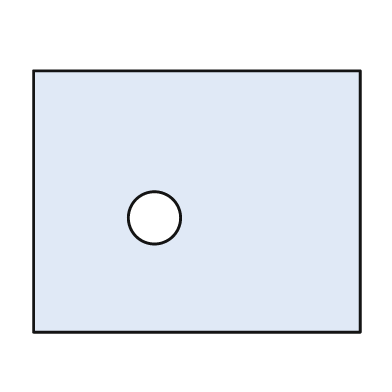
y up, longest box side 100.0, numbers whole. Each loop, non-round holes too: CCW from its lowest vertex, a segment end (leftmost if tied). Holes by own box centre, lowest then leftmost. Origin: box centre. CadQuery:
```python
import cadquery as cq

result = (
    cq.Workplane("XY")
    .moveTo(-50.0, -40.0)
    .lineTo(50.0, -40.0)
    .lineTo(50.0, 40.0)
    .lineTo(-50.0, 40.0)
    .close()
    .moveTo(-13.0, -5.0)
    .circle(8.0)
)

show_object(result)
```